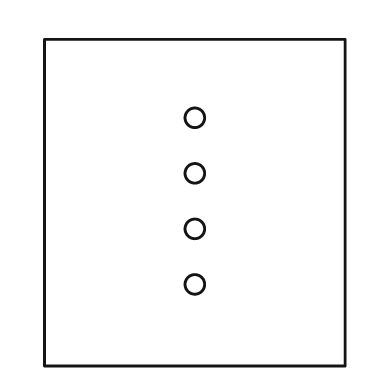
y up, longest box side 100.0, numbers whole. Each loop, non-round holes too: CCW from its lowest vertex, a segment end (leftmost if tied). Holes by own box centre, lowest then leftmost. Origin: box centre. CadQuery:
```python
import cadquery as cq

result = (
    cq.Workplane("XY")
    .moveTo(-46.0, -50.0)
    .lineTo(46.0, -50.0)
    .lineTo(46.0, 50.0)
    .lineTo(-46.0, 50.0)
    .close()
    .moveTo(0.0, -25.0)
    .circle(3.0)
    .moveTo(0.0, -8.0)
    .circle(3.0)
    .moveTo(0.0, 9.0)
    .circle(3.0)
    .moveTo(0.0, 26.0)
    .circle(3.0)
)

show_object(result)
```